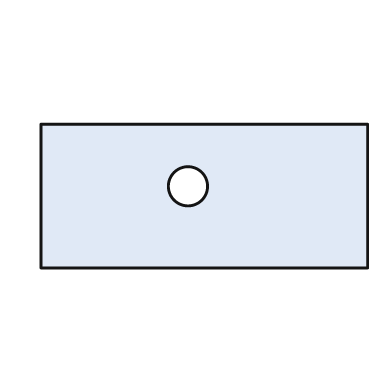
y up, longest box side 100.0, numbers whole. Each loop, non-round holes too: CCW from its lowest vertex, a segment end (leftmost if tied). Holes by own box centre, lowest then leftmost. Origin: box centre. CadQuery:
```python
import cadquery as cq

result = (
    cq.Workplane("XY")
    .moveTo(-50.0, -22.0)
    .lineTo(50.0, -22.0)
    .lineTo(50.0, 22.0)
    .lineTo(-50.0, 22.0)
    .close()
    .moveTo(-5.0, 3.0)
    .circle(6.0)
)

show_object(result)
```